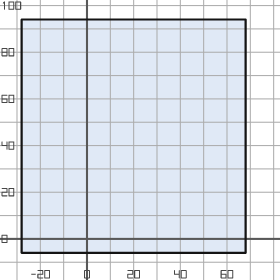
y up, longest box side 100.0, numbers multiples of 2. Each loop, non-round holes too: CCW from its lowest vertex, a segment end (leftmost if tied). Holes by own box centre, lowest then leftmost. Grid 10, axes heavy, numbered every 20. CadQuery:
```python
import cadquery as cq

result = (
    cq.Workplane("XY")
    .moveTo(-28.0, -6.0)
    .lineTo(68.0, -6.0)
    .lineTo(68.0, 94.0)
    .lineTo(-28.0, 94.0)
    .close()
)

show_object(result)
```